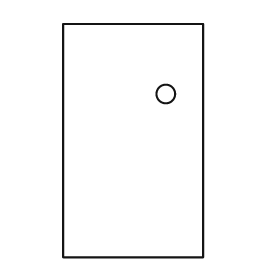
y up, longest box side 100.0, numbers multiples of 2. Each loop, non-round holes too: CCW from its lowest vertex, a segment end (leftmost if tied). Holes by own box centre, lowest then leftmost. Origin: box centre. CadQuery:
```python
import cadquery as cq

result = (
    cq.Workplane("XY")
    .moveTo(-30.0, -50.0)
    .lineTo(30.0, -50.0)
    .lineTo(30.0, 50.0)
    .lineTo(-30.0, 50.0)
    .close()
    .moveTo(14.0, 20.0)
    .circle(4.0)
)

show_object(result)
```